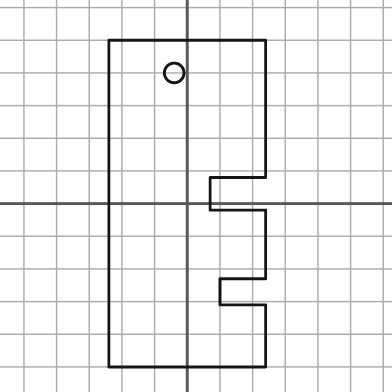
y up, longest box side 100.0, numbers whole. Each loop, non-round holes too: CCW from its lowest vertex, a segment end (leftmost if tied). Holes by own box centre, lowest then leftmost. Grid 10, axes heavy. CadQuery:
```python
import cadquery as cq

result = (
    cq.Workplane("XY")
    .moveTo(-24.0, -50.0)
    .lineTo(24.0, -50.0)
    .lineTo(24.0, -31.0)
    .lineTo(10.0, -31.0)
    .lineTo(10.0, -23.0)
    .lineTo(24.0, -23.0)
    .lineTo(24.0, -2.0)
    .lineTo(7.0, -2.0)
    .lineTo(7.0, 8.0)
    .lineTo(24.0, 8.0)
    .lineTo(24.0, 50.0)
    .lineTo(-24.0, 50.0)
    .close()
    .moveTo(-4.0, 40.0)
    .circle(3.0)
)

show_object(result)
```